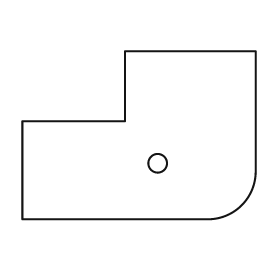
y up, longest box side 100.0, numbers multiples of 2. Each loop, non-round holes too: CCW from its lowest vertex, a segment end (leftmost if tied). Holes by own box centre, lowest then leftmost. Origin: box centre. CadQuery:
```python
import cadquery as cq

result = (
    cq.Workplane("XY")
    .moveTo(-50.0, -36.0)
    .lineTo(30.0, -36.0)
    .threePointArc((44.0, -30.0), (50.0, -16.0))
    .lineTo(50.0, 36.0)
    .lineTo(-6.0, 36.0)
    .lineTo(-6.0, 6.0)
    .lineTo(-50.0, 6.0)
    .close()
    .moveTo(8.0, -12.0)
    .circle(4.0)
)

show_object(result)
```